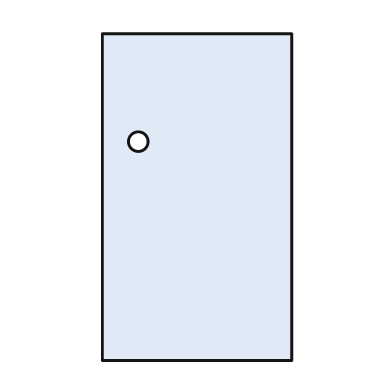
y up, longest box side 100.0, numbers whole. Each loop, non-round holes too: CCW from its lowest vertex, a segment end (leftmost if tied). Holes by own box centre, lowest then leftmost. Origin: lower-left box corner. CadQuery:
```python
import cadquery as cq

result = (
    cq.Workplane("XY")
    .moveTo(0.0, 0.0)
    .lineTo(58.0, 0.0)
    .lineTo(58.0, 100.0)
    .lineTo(0.0, 100.0)
    .close()
    .moveTo(11.0, 67.0)
    .circle(3.0)
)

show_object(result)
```